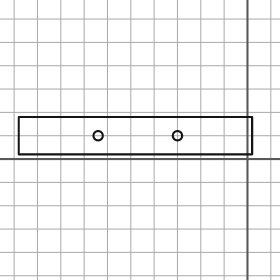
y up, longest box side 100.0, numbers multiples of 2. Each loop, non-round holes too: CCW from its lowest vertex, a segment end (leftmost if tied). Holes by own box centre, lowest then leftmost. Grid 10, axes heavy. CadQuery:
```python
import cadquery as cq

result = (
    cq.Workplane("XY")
    .moveTo(-98.0, 2.0)
    .lineTo(2.0, 2.0)
    .lineTo(2.0, 18.0)
    .lineTo(-98.0, 18.0)
    .close()
    .moveTo(-64.0, 10.0)
    .circle(2.0)
    .moveTo(-30.0, 10.0)
    .circle(2.0)
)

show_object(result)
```